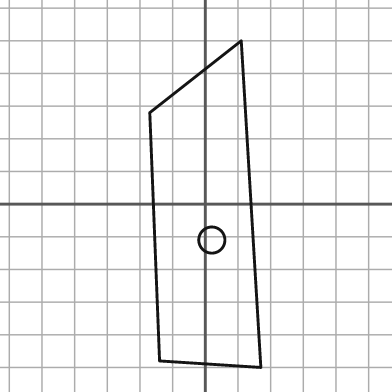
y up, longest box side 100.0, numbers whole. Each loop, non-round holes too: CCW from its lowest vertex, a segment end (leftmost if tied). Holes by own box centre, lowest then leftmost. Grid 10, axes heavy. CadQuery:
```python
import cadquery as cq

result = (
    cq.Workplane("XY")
    .moveTo(17.0, -50.0)
    .lineTo(11.0, 50.0)
    .lineTo(-17.0, 28.0)
    .lineTo(-14.0, -48.0)
    .close()
    .moveTo(2.0, -11.0)
    .circle(4.0)
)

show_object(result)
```